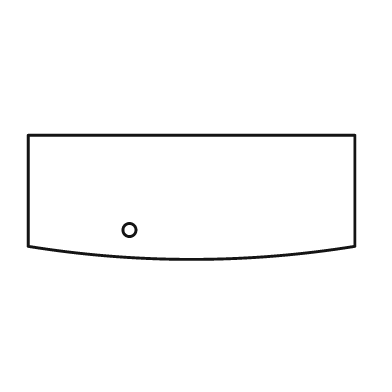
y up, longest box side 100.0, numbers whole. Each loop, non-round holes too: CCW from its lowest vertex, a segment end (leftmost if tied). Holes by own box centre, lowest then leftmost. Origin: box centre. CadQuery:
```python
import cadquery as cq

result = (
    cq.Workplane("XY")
    .moveTo(-50.0, -15.0)
    .threePointArc((0.0, -19.0), (50.0, -15.0))
    .lineTo(50.0, 19.0)
    .lineTo(-50.0, 19.0)
    .close()
    .moveTo(-19.0, -10.0)
    .circle(2.0)
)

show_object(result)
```